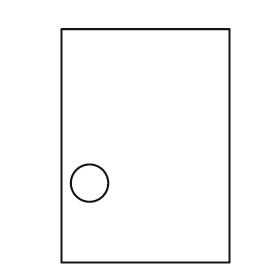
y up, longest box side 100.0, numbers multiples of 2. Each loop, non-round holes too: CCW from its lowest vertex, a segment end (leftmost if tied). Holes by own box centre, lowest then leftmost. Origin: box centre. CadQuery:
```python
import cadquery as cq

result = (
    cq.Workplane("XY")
    .moveTo(-36.0, -50.0)
    .lineTo(36.0, -50.0)
    .lineTo(36.0, 50.0)
    .lineTo(-36.0, 50.0)
    .close()
    .moveTo(-24.0, -16.0)
    .circle(8.0)
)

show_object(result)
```